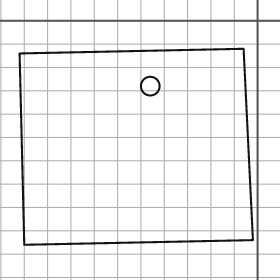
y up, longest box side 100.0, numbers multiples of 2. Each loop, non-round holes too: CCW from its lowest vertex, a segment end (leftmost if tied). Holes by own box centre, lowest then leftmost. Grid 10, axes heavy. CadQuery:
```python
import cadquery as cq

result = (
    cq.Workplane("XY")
    .moveTo(-100.0, -96.0)
    .lineTo(-2.0, -94.0)
    .lineTo(-6.0, -12.0)
    .lineTo(-102.0, -14.0)
    .close()
    .moveTo(-46.0, -28.0)
    .circle(4.0)
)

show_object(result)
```